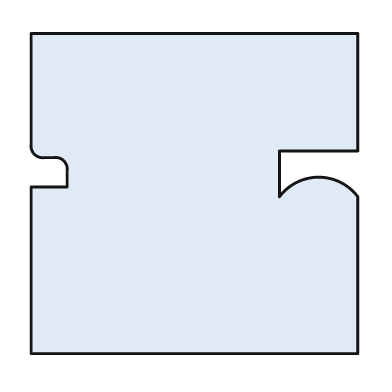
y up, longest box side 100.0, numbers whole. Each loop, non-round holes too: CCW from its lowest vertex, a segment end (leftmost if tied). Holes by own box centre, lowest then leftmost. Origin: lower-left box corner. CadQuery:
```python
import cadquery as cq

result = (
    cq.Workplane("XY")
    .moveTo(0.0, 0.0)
    .lineTo(100.0, 0.0)
    .lineTo(100.0, 48.0)
    .threePointArc((88.0, 54.0), (76.0, 48.0))
    .lineTo(76.0, 62.0)
    .lineTo(100.0, 62.0)
    .lineTo(100.0, 98.0)
    .lineTo(0.0, 98.0)
    .lineTo(0.0, 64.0)
    .threePointArc((1.0, 61.0), (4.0, 60.0))
    .lineTo(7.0, 60.0)
    .threePointArc((10.0, 59.0), (11.0, 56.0))
    .lineTo(11.0, 51.0)
    .lineTo(0.0, 51.0)
    .close()
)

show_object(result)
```